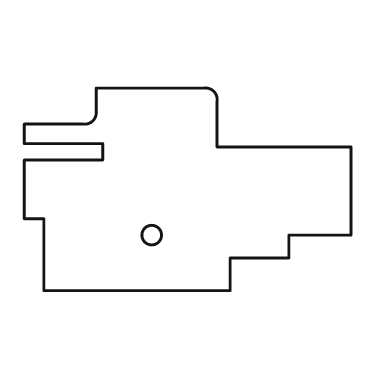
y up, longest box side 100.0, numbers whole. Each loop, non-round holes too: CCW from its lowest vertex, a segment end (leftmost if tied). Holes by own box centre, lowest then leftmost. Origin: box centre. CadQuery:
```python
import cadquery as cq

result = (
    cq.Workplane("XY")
    .moveTo(-44.0, -31.0)
    .lineTo(13.0, -31.0)
    .lineTo(13.0, -21.0)
    .lineTo(31.0, -21.0)
    .lineTo(31.0, -14.0)
    .lineTo(50.0, -14.0)
    .lineTo(50.0, 13.0)
    .lineTo(9.0, 13.0)
    .lineTo(9.0, 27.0)
    .threePointArc((8.0, 30.0), (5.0, 31.0))
    .lineTo(-28.0, 31.0)
    .lineTo(-28.0, 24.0)
    .threePointArc((-29.0, 21.0), (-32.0, 20.0))
    .lineTo(-50.0, 20.0)
    .lineTo(-50.0, 14.0)
    .lineTo(-26.0, 14.0)
    .lineTo(-26.0, 9.0)
    .lineTo(-50.0, 9.0)
    .lineTo(-50.0, -9.0)
    .lineTo(-44.0, -9.0)
    .close()
    .moveTo(-11.0, -14.0)
    .circle(3.0)
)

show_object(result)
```